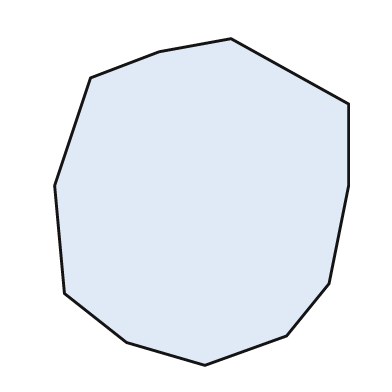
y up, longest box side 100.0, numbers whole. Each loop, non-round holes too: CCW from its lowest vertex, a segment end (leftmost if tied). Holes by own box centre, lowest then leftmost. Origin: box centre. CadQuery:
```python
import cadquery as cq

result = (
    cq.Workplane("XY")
    .moveTo(1.0, -50.0)
    .lineTo(26.0, -41.0)
    .lineTo(39.0, -25.0)
    .lineTo(45.0, 5.0)
    .lineTo(45.0, 30.0)
    .lineTo(9.0, 50.0)
    .lineTo(-13.0, 46.0)
    .lineTo(-34.0, 38.0)
    .lineTo(-45.0, 5.0)
    .lineTo(-42.0, -28.0)
    .lineTo(-23.0, -43.0)
    .close()
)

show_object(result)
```